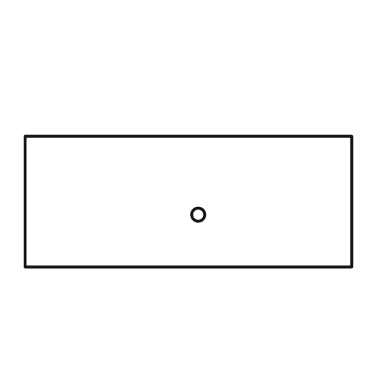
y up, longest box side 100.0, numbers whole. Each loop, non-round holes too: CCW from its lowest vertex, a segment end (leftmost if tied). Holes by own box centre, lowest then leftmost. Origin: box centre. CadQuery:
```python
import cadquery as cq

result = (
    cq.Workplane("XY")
    .moveTo(-50.0, -20.0)
    .lineTo(50.0, -20.0)
    .lineTo(50.0, 20.0)
    .lineTo(-50.0, 20.0)
    .close()
    .moveTo(3.0, -4.0)
    .circle(2.0)
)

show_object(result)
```